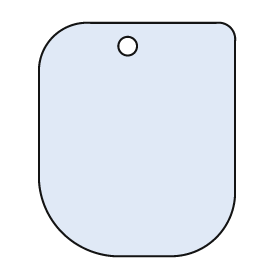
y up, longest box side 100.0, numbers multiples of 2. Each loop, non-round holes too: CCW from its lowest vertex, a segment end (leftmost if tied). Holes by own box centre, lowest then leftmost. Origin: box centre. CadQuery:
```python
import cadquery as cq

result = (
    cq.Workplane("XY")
    .moveTo(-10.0, -50.0)
    .lineTo(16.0, -50.0)
    .threePointArc((34.0, -42.0), (42.0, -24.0))
    .lineTo(42.0, 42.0)
    .threePointArc((40.0, 48.0), (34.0, 50.0))
    .lineTo(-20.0, 50.0)
    .threePointArc((-36.0, 44.0), (-42.0, 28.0))
    .lineTo(-42.0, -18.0)
    .threePointArc((-32.0, -40.0), (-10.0, -50.0))
    .close()
    .moveTo(-4.0, 40.0)
    .circle(4.0)
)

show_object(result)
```